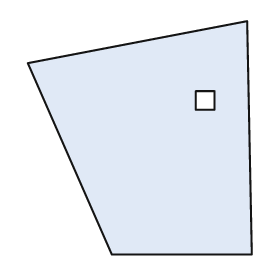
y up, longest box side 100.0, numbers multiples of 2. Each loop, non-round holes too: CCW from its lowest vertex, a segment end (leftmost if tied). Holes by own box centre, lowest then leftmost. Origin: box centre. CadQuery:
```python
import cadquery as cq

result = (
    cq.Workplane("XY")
    .moveTo(-12.0, -50.0)
    .lineTo(48.0, -50.0)
    .lineTo(46.0, 50.0)
    .lineTo(-48.0, 32.0)
    .close()
    .moveTo(24.0, 12.0)
    .lineTo(32.0, 12.0)
    .lineTo(32.0, 20.0)
    .lineTo(24.0, 20.0)
    .close()
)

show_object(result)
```